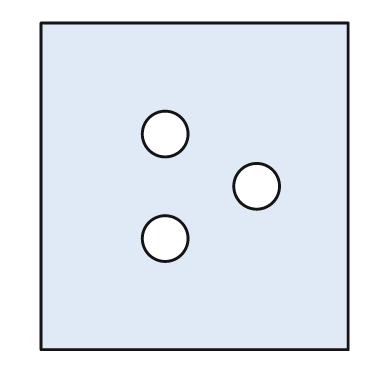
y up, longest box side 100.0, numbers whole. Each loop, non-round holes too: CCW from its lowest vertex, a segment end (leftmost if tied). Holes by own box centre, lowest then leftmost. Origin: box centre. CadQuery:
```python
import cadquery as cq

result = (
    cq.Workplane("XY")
    .moveTo(-47.0, -50.0)
    .lineTo(47.0, -50.0)
    .lineTo(47.0, 50.0)
    .lineTo(-47.0, 50.0)
    .close()
    .moveTo(-9.0, -16.0)
    .circle(7.0)
    .moveTo(19.0, 0.0)
    .circle(7.0)
    .moveTo(-9.0, 16.0)
    .circle(7.0)
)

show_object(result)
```